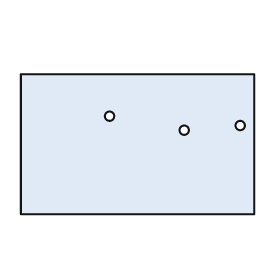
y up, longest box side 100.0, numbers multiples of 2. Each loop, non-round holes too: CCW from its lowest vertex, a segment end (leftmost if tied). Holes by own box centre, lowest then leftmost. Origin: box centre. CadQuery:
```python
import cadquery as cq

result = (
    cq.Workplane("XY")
    .moveTo(-50.0, -30.0)
    .lineTo(50.0, -30.0)
    .lineTo(50.0, 30.0)
    .lineTo(-50.0, 30.0)
    .close()
    .moveTo(20.0, 6.0)
    .circle(2.0)
    .moveTo(44.0, 8.0)
    .circle(2.0)
    .moveTo(-12.0, 12.0)
    .circle(2.0)
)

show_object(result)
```